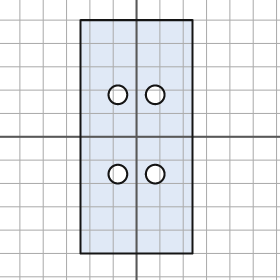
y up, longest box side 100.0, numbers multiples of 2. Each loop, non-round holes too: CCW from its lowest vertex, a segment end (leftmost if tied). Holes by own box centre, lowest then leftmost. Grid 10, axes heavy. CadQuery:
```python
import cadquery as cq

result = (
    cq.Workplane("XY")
    .moveTo(-24.0, -50.0)
    .lineTo(24.0, -50.0)
    .lineTo(24.0, 50.0)
    .lineTo(-24.0, 50.0)
    .close()
    .moveTo(-8.0, -16.0)
    .circle(4.0)
    .moveTo(8.0, -16.0)
    .circle(4.0)
    .moveTo(-8.0, 18.0)
    .circle(4.0)
    .moveTo(8.0, 18.0)
    .circle(4.0)
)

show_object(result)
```